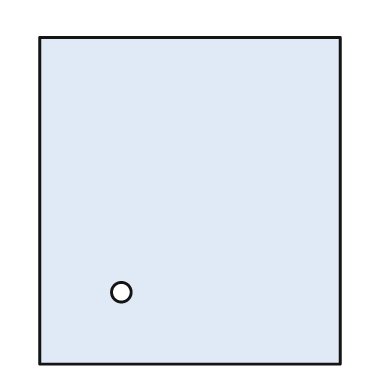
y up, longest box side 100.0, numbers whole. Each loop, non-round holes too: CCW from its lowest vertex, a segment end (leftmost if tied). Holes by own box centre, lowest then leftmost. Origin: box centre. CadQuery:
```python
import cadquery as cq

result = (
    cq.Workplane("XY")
    .moveTo(-46.0, -50.0)
    .lineTo(46.0, -50.0)
    .lineTo(46.0, 50.0)
    .lineTo(-46.0, 50.0)
    .close()
    .moveTo(-21.0, -28.0)
    .circle(3.0)
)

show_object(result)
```